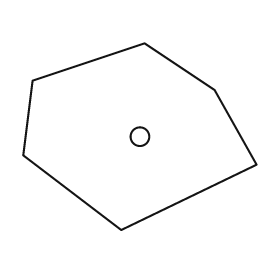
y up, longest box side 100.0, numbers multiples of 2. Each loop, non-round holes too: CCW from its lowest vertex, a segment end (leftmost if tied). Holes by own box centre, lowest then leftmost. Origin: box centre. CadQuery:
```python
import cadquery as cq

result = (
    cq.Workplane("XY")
    .moveTo(-8.0, -40.0)
    .lineTo(50.0, -12.0)
    .lineTo(32.0, 20.0)
    .lineTo(2.0, 40.0)
    .lineTo(-46.0, 24.0)
    .lineTo(-50.0, -8.0)
    .close()
    .moveTo(0.0, 0.0)
    .circle(4.0)
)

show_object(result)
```